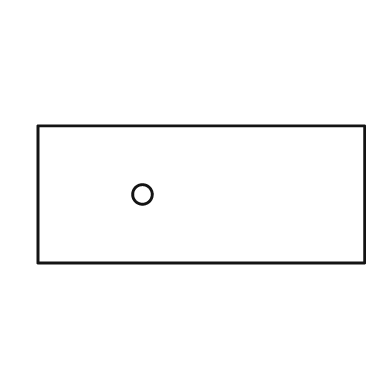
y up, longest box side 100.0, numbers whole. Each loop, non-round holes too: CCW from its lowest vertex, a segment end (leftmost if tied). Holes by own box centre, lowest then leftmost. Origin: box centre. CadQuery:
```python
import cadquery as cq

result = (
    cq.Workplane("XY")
    .moveTo(-50.0, -21.0)
    .lineTo(50.0, -21.0)
    .lineTo(50.0, 21.0)
    .lineTo(-50.0, 21.0)
    .close()
    .moveTo(-18.0, 0.0)
    .circle(3.0)
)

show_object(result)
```